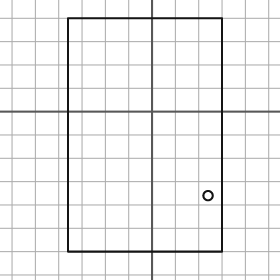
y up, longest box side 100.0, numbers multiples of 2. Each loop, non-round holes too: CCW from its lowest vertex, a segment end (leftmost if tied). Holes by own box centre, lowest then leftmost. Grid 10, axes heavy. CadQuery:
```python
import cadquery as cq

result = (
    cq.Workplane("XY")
    .moveTo(-36.0, -60.0)
    .lineTo(30.0, -60.0)
    .lineTo(30.0, 40.0)
    .lineTo(-36.0, 40.0)
    .close()
    .moveTo(24.0, -36.0)
    .circle(2.0)
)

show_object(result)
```